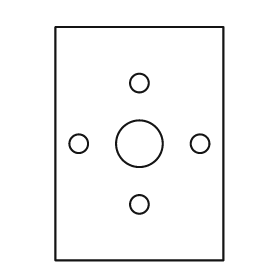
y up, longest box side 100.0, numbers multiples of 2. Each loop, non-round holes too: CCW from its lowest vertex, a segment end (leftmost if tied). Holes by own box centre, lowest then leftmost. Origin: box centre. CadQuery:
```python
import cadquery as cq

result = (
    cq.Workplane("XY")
    .moveTo(-36.0, -50.0)
    .lineTo(36.0, -50.0)
    .lineTo(36.0, 50.0)
    .lineTo(-36.0, 50.0)
    .close()
    .moveTo(0.0, -26.0)
    .circle(4.0)
    .moveTo(-26.0, 0.0)
    .circle(4.0)
    .moveTo(0.0, 0.0)
    .circle(10.0)
    .moveTo(26.0, 0.0)
    .circle(4.0)
    .moveTo(0.0, 26.0)
    .circle(4.0)
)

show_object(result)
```